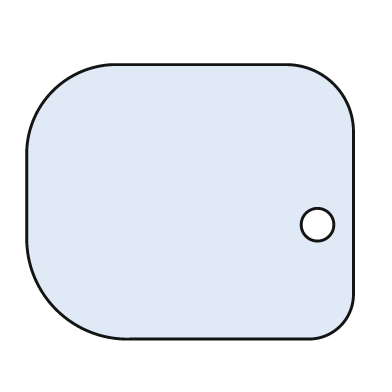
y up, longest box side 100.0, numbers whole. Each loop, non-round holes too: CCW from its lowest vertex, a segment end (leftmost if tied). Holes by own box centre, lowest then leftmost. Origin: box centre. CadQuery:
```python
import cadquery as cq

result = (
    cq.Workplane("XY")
    .moveTo(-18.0, -42.0)
    .lineTo(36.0, -42.0)
    .threePointArc((46.0, -38.0), (50.0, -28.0))
    .lineTo(50.0, 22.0)
    .threePointArc((44.0, 36.0), (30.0, 42.0))
    .lineTo(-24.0, 42.0)
    .threePointArc((-42.0, 34.0), (-50.0, 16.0))
    .lineTo(-50.0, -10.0)
    .threePointArc((-41.0, -33.0), (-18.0, -42.0))
    .close()
    .moveTo(39.0, -7.0)
    .circle(5.0)
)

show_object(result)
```